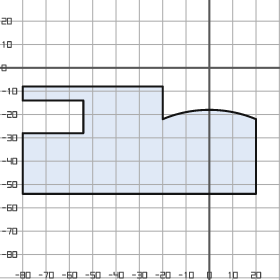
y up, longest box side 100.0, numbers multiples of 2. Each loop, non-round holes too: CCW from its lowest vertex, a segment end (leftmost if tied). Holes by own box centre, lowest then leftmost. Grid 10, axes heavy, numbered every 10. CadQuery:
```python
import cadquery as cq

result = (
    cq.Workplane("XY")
    .moveTo(-80.0, -54.0)
    .lineTo(20.0, -54.0)
    .lineTo(20.0, -22.0)
    .threePointArc((0.0, -18.0), (-20.0, -22.0))
    .lineTo(-20.0, -8.0)
    .lineTo(-80.0, -8.0)
    .lineTo(-80.0, -14.0)
    .lineTo(-54.0, -14.0)
    .lineTo(-54.0, -28.0)
    .lineTo(-80.0, -28.0)
    .close()
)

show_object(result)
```